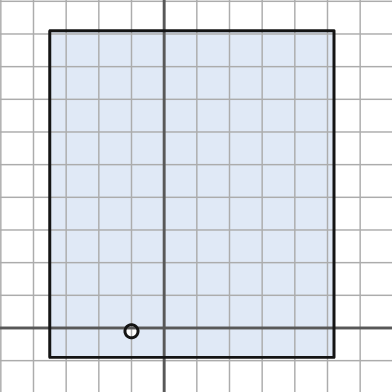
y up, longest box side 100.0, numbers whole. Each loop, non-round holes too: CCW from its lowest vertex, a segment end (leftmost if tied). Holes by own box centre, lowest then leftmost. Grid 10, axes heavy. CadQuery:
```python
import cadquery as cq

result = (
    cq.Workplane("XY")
    .moveTo(-35.0, -9.0)
    .lineTo(52.0, -9.0)
    .lineTo(52.0, 91.0)
    .lineTo(-35.0, 91.0)
    .close()
    .moveTo(-10.0, -1.0)
    .circle(2.0)
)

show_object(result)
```